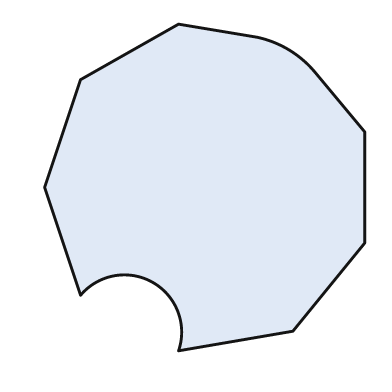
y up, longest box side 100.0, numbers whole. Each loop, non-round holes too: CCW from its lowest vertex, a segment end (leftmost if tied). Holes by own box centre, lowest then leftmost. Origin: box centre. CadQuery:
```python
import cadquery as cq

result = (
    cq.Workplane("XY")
    .moveTo(-8.0, -50.0)
    .lineTo(27.0, -44.0)
    .lineTo(49.0, -17.0)
    .lineTo(49.0, 17.0)
    .lineTo(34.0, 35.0)
    .threePointArc((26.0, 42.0), (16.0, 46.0))
    .lineTo(-8.0, 50.0)
    .lineTo(-38.0, 33.0)
    .lineTo(-49.0, 0.0)
    .lineTo(-38.0, -33.0)
    .threePointArc((-16.0, -29.0), (-8.0, -50.0))
    .close()
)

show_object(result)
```